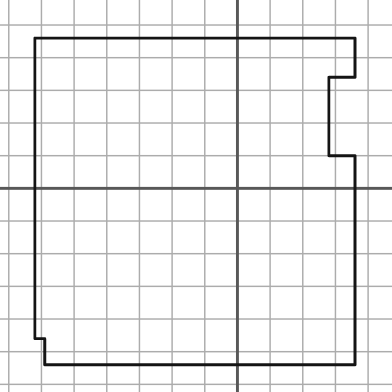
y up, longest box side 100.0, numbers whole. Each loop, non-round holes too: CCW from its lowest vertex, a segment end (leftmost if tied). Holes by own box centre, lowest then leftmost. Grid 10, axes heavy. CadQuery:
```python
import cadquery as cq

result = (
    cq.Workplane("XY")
    .moveTo(-59.0, -54.0)
    .lineTo(36.0, -54.0)
    .lineTo(36.0, 10.0)
    .lineTo(28.0, 10.0)
    .lineTo(28.0, 34.0)
    .lineTo(36.0, 34.0)
    .lineTo(36.0, 46.0)
    .lineTo(-62.0, 46.0)
    .lineTo(-62.0, -46.0)
    .lineTo(-59.0, -46.0)
    .close()
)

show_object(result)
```